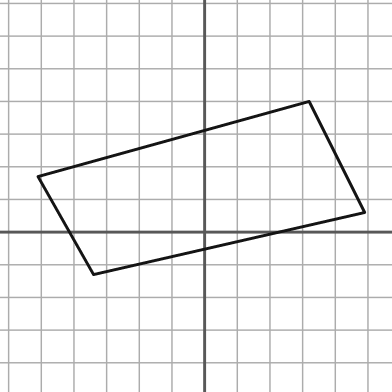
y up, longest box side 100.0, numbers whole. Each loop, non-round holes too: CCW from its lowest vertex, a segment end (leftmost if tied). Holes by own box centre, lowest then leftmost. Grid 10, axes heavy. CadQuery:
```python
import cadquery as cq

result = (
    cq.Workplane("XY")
    .moveTo(-34.0, -13.0)
    .lineTo(49.0, 6.0)
    .lineTo(32.0, 40.0)
    .lineTo(-51.0, 17.0)
    .close()
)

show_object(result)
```